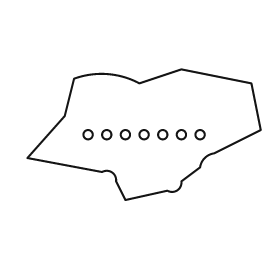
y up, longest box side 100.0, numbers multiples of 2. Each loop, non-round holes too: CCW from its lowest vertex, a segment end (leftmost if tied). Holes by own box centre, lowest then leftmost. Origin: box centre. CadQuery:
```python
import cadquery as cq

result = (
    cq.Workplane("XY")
    .moveTo(-8.0, -28.0)
    .lineTo(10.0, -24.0)
    .threePointArc((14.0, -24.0), (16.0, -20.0))
    .lineTo(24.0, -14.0)
    .threePointArc((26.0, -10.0), (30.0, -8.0))
    .lineTo(50.0, 2.0)
    .lineTo(46.0, 22.0)
    .lineTo(16.0, 28.0)
    .lineTo(-2.0, 22.0)
    .threePointArc((-16.0, 26.0), (-30.0, 24.0))
    .lineTo(-34.0, 8.0)
    .lineTo(-50.0, -10.0)
    .lineTo(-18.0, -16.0)
    .threePointArc((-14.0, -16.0), (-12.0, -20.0))
    .close()
    .moveTo(-24.0, 0.0)
    .circle(2.0)
    .moveTo(-16.0, 0.0)
    .circle(2.0)
    .moveTo(-8.0, 0.0)
    .circle(2.0)
    .moveTo(0.0, 0.0)
    .circle(2.0)
    .moveTo(8.0, 0.0)
    .circle(2.0)
    .moveTo(16.0, 0.0)
    .circle(2.0)
    .moveTo(24.0, 0.0)
    .circle(2.0)
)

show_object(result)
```